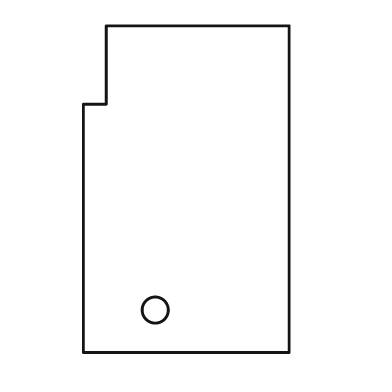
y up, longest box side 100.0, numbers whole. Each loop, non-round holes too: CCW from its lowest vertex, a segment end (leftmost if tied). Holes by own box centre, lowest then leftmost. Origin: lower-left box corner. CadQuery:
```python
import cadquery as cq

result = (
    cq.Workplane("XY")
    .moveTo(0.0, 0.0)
    .lineTo(63.0, 0.0)
    .lineTo(63.0, 100.0)
    .lineTo(7.0, 100.0)
    .lineTo(7.0, 76.0)
    .lineTo(0.0, 76.0)
    .close()
    .moveTo(22.0, 13.0)
    .circle(4.0)
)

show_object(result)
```